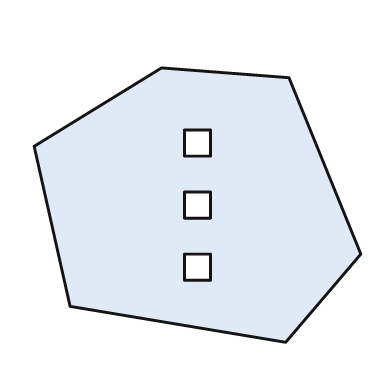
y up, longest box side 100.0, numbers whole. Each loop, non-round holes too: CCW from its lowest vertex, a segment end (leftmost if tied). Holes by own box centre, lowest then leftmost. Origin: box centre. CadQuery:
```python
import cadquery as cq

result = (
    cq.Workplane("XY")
    .moveTo(27.0, -42.0)
    .lineTo(50.0, -15.0)
    .lineTo(28.0, 39.0)
    .lineTo(-11.0, 42.0)
    .lineTo(-50.0, 18.0)
    .lineTo(-39.0, -31.0)
    .close()
    .moveTo(-4.0, -23.0)
    .lineTo(4.0, -23.0)
    .lineTo(4.0, -15.0)
    .lineTo(-4.0, -15.0)
    .close()
    .moveTo(-4.0, -4.0)
    .lineTo(4.0, -4.0)
    .lineTo(4.0, 4.0)
    .lineTo(-4.0, 4.0)
    .close()
    .moveTo(-4.0, 15.0)
    .lineTo(4.0, 15.0)
    .lineTo(4.0, 23.0)
    .lineTo(-4.0, 23.0)
    .close()
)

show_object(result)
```